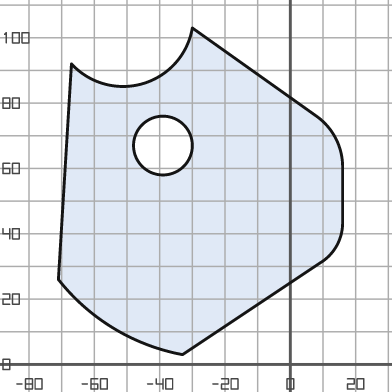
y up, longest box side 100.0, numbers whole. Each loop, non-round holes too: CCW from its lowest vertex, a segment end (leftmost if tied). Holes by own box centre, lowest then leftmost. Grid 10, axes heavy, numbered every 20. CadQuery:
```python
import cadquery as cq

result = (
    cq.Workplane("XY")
    .moveTo(-33.0, 3.0)
    .lineTo(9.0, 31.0)
    .threePointArc((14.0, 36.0), (16.0, 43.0))
    .lineTo(16.0, 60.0)
    .threePointArc((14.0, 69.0), (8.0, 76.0))
    .lineTo(-30.0, 103.0)
    .threePointArc((-45.0, 86.0), (-67.0, 92.0))
    .lineTo(-71.0, 26.0)
    .threePointArc((-54.0, 11.0), (-33.0, 3.0))
    .close()
    .moveTo(-39.0, 67.0)
    .circle(9.0)
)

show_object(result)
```